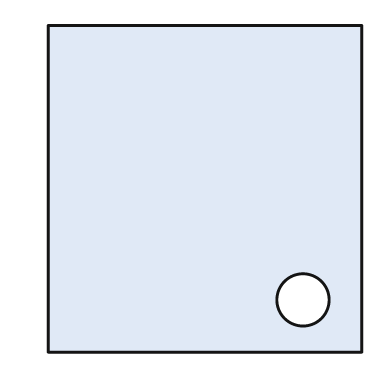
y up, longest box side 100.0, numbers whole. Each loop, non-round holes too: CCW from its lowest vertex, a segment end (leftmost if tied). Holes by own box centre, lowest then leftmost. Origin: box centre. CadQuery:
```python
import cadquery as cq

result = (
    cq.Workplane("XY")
    .moveTo(-48.0, -50.0)
    .lineTo(48.0, -50.0)
    .lineTo(48.0, 50.0)
    .lineTo(-48.0, 50.0)
    .close()
    .moveTo(30.0, -34.0)
    .circle(8.0)
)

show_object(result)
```